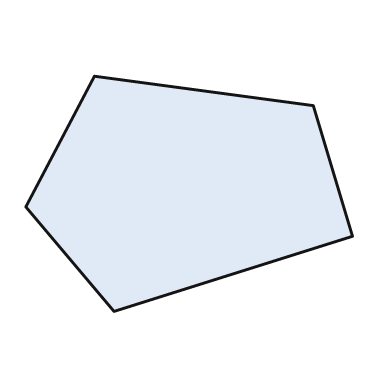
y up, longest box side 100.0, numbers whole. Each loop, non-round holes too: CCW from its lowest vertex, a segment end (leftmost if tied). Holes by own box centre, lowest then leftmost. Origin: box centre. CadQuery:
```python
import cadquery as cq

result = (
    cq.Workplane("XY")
    .moveTo(-23.0, -36.0)
    .lineTo(50.0, -13.0)
    .lineTo(38.0, 27.0)
    .lineTo(-29.0, 36.0)
    .lineTo(-50.0, -4.0)
    .close()
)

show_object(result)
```